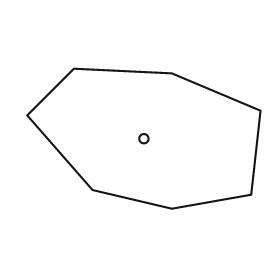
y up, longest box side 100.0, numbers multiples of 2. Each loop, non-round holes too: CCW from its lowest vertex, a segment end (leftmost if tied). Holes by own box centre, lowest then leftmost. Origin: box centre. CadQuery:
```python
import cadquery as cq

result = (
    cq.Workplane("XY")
    .moveTo(12.0, -30.0)
    .lineTo(46.0, -24.0)
    .lineTo(50.0, 12.0)
    .lineTo(12.0, 28.0)
    .lineTo(-30.0, 30.0)
    .lineTo(-50.0, 10.0)
    .lineTo(-22.0, -22.0)
    .close()
    .moveTo(0.0, 0.0)
    .circle(2.0)
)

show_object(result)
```